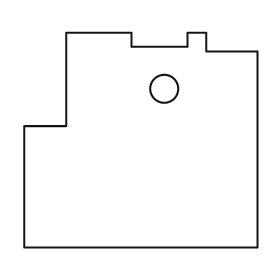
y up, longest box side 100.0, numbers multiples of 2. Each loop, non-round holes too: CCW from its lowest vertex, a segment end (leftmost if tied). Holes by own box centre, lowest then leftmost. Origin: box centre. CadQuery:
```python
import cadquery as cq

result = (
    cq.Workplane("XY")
    .moveTo(-50.0, -46.0)
    .lineTo(50.0, -46.0)
    .lineTo(50.0, 38.0)
    .lineTo(28.0, 38.0)
    .lineTo(28.0, 46.0)
    .lineTo(20.0, 46.0)
    .lineTo(20.0, 40.0)
    .lineTo(-4.0, 40.0)
    .lineTo(-4.0, 46.0)
    .lineTo(-32.0, 46.0)
    .lineTo(-32.0, 6.0)
    .lineTo(-50.0, 6.0)
    .close()
    .moveTo(10.0, 22.0)
    .circle(6.0)
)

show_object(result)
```